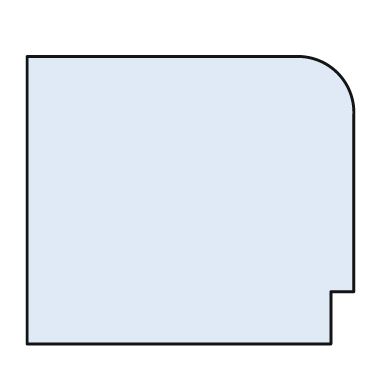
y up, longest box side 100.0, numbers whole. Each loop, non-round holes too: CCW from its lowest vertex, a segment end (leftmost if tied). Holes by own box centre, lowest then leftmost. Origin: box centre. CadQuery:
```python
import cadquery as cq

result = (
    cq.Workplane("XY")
    .moveTo(-50.0, -44.0)
    .lineTo(43.0, -44.0)
    .lineTo(43.0, -28.0)
    .lineTo(50.0, -28.0)
    .lineTo(50.0, 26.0)
    .threePointArc((45.0, 39.0), (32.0, 44.0))
    .lineTo(-50.0, 44.0)
    .close()
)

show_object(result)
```